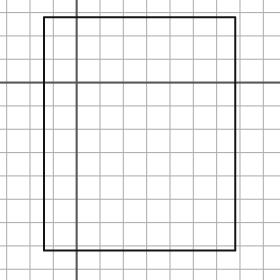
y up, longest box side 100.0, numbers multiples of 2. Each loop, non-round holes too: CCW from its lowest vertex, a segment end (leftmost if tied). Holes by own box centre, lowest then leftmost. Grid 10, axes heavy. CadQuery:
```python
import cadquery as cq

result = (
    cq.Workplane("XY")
    .moveTo(-14.0, -72.0)
    .lineTo(68.0, -72.0)
    .lineTo(68.0, 28.0)
    .lineTo(-14.0, 28.0)
    .close()
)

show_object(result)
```